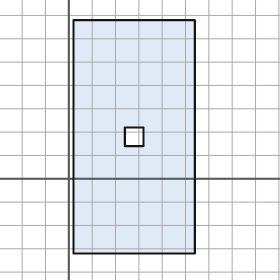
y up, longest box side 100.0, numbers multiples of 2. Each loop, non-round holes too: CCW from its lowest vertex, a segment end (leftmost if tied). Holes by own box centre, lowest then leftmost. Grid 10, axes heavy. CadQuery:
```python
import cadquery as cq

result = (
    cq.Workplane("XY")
    .moveTo(2.0, -32.0)
    .lineTo(54.0, -32.0)
    .lineTo(54.0, 68.0)
    .lineTo(2.0, 68.0)
    .close()
    .moveTo(24.0, 14.0)
    .lineTo(32.0, 14.0)
    .lineTo(32.0, 22.0)
    .lineTo(24.0, 22.0)
    .close()
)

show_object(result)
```